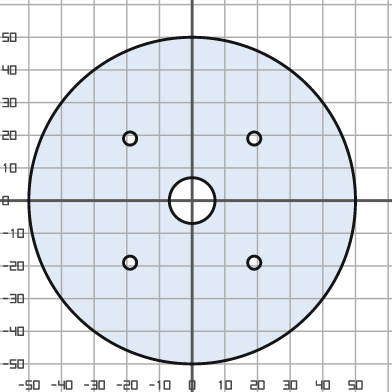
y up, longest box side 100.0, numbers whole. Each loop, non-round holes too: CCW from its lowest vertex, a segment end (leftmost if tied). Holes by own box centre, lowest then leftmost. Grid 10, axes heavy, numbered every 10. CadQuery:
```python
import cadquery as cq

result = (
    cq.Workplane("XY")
    .moveTo(0.0, 0.0)
    .circle(50.0)
    .moveTo(-19.0, -19.0)
    .circle(2.0)
    .moveTo(19.0, -19.0)
    .circle(2.0)
    .moveTo(0.0, 0.0)
    .circle(7.0)
    .moveTo(-19.0, 19.0)
    .circle(2.0)
    .moveTo(19.0, 19.0)
    .circle(2.0)
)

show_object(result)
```